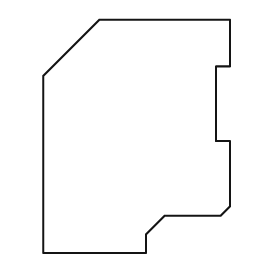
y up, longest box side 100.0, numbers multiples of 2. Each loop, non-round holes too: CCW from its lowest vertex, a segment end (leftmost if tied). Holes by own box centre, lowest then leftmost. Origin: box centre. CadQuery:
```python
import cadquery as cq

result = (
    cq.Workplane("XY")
    .moveTo(-40.0, -50.0)
    .lineTo(4.0, -50.0)
    .lineTo(4.0, -42.0)
    .lineTo(12.0, -34.0)
    .lineTo(36.0, -34.0)
    .lineTo(40.0, -30.0)
    .lineTo(40.0, -2.0)
    .lineTo(34.0, -2.0)
    .lineTo(34.0, 30.0)
    .lineTo(40.0, 30.0)
    .lineTo(40.0, 50.0)
    .lineTo(-16.0, 50.0)
    .lineTo(-40.0, 26.0)
    .close()
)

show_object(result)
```